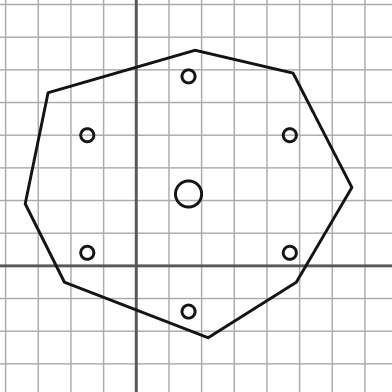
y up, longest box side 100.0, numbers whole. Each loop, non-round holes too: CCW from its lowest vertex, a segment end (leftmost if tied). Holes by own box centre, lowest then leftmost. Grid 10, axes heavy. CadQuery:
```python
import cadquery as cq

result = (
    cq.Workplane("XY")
    .moveTo(22.0, -22.0)
    .lineTo(49.0, -5.0)
    .lineTo(66.0, 24.0)
    .lineTo(48.0, 59.0)
    .lineTo(18.0, 66.0)
    .lineTo(-27.0, 53.0)
    .lineTo(-34.0, 19.0)
    .lineTo(-22.0, -5.0)
    .close()
    .moveTo(16.0, -14.0)
    .circle(2.0)
    .moveTo(-15.0, 4.0)
    .circle(2.0)
    .moveTo(47.0, 4.0)
    .circle(2.0)
    .moveTo(16.0, 22.0)
    .circle(4.0)
    .moveTo(-15.0, 40.0)
    .circle(2.0)
    .moveTo(47.0, 40.0)
    .circle(2.0)
    .moveTo(16.0, 58.0)
    .circle(2.0)
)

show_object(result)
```